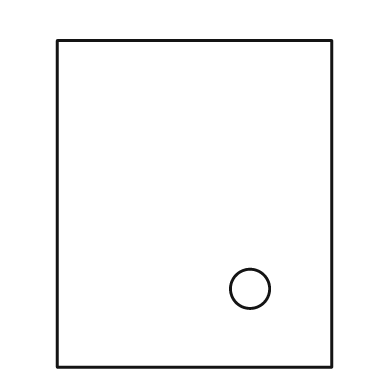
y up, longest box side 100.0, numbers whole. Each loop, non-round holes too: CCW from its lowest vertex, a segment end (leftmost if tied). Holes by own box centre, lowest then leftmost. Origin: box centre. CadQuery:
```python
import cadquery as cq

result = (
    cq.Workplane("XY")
    .moveTo(-42.0, -50.0)
    .lineTo(42.0, -50.0)
    .lineTo(42.0, 50.0)
    .lineTo(-42.0, 50.0)
    .close()
    .moveTo(17.0, -26.0)
    .circle(6.0)
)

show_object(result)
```